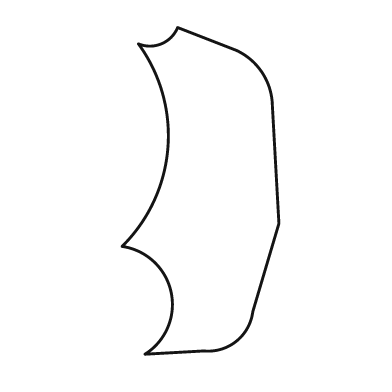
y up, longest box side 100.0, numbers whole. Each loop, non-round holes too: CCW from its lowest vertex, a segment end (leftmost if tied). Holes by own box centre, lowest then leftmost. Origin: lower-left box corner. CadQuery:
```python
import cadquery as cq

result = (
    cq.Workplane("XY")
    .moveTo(7.0, 0.0)
    .lineTo(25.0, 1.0)
    .threePointArc((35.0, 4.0), (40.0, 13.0))
    .lineTo(48.0, 40.0)
    .lineTo(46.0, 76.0)
    .threePointArc((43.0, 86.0), (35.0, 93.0))
    .lineTo(17.0, 100.0)
    .threePointArc((12.0, 95.0), (5.0, 95.0))
    .threePointArc((14.0, 63.0), (0.0, 33.0))
    .threePointArc((15.0, 19.0), (7.0, 0.0))
    .close()
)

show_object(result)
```